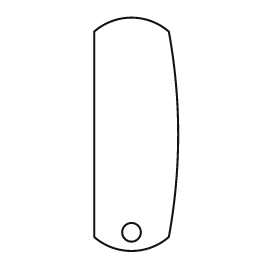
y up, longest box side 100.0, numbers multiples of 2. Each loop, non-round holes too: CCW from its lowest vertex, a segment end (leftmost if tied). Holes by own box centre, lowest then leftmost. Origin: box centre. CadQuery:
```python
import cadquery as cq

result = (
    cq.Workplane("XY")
    .moveTo(-18.0, -44.0)
    .threePointArc((-2.0, -50.0), (14.0, -44.0))
    .threePointArc((18.0, 0.0), (14.0, 44.0))
    .threePointArc((-2.0, 50.0), (-18.0, 44.0))
    .close()
    .moveTo(-2.0, -42.0)
    .circle(4.0)
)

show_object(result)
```